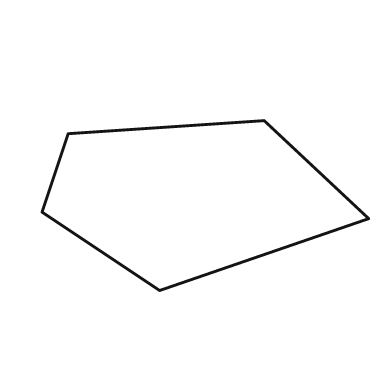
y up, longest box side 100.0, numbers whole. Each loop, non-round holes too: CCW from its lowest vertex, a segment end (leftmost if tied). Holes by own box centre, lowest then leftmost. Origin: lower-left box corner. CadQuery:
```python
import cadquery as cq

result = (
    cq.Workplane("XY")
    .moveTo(36.0, 0.0)
    .lineTo(100.0, 22.0)
    .lineTo(68.0, 52.0)
    .lineTo(8.0, 48.0)
    .lineTo(0.0, 24.0)
    .close()
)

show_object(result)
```